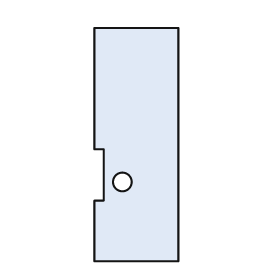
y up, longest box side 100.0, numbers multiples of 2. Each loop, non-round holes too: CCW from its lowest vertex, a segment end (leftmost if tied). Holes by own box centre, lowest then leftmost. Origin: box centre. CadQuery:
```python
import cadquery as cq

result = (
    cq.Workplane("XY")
    .moveTo(-18.0, -50.0)
    .lineTo(18.0, -50.0)
    .lineTo(18.0, 50.0)
    .lineTo(-18.0, 50.0)
    .lineTo(-18.0, -2.0)
    .lineTo(-14.0, -2.0)
    .lineTo(-14.0, -24.0)
    .lineTo(-18.0, -24.0)
    .close()
    .moveTo(-6.0, -16.0)
    .circle(4.0)
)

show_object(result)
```